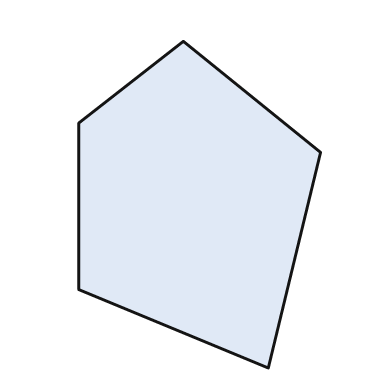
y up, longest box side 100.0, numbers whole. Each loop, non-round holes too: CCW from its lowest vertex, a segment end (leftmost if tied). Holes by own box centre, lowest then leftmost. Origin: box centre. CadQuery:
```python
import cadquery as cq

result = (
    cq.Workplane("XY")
    .moveTo(21.0, -50.0)
    .lineTo(37.0, 16.0)
    .lineTo(-5.0, 50.0)
    .lineTo(-37.0, 25.0)
    .lineTo(-37.0, -26.0)
    .close()
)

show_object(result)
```